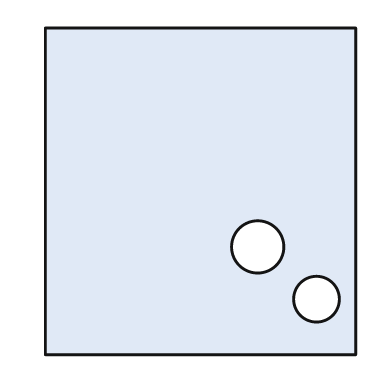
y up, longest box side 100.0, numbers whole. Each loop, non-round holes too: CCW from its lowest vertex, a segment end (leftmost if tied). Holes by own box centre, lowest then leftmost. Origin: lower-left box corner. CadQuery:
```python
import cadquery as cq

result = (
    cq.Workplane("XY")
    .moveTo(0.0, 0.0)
    .lineTo(95.0, 0.0)
    .lineTo(95.0, 100.0)
    .lineTo(0.0, 100.0)
    .close()
    .moveTo(83.0, 17.0)
    .circle(7.0)
    .moveTo(65.0, 33.0)
    .circle(8.0)
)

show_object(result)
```